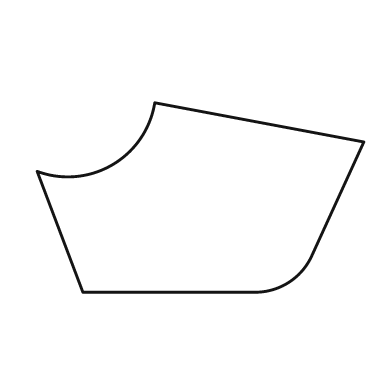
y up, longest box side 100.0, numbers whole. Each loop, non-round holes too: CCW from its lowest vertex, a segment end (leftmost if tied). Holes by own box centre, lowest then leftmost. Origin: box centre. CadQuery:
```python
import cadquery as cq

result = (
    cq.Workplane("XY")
    .moveTo(-36.0, -29.0)
    .lineTo(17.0, -29.0)
    .threePointArc((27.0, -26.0), (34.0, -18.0))
    .lineTo(50.0, 17.0)
    .lineTo(-14.0, 29.0)
    .threePointArc((-27.0, 10.0), (-50.0, 8.0))
    .close()
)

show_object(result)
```